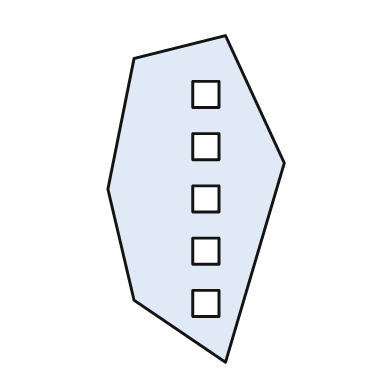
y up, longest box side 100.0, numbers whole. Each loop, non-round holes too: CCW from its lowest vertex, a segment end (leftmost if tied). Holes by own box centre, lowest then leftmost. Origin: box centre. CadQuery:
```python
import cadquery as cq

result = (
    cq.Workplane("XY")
    .moveTo(9.0, -50.0)
    .lineTo(27.0, 11.0)
    .lineTo(9.0, 50.0)
    .lineTo(-19.0, 43.0)
    .lineTo(-27.0, 3.0)
    .lineTo(-19.0, -31.0)
    .close()
    .moveTo(-1.0, -36.0)
    .lineTo(7.0, -36.0)
    .lineTo(7.0, -28.0)
    .lineTo(-1.0, -28.0)
    .close()
    .moveTo(-1.0, -20.0)
    .lineTo(7.0, -20.0)
    .lineTo(7.0, -12.0)
    .lineTo(-1.0, -12.0)
    .close()
    .moveTo(-1.0, -4.0)
    .lineTo(7.0, -4.0)
    .lineTo(7.0, 4.0)
    .lineTo(-1.0, 4.0)
    .close()
    .moveTo(-1.0, 12.0)
    .lineTo(7.0, 12.0)
    .lineTo(7.0, 20.0)
    .lineTo(-1.0, 20.0)
    .close()
    .moveTo(-1.0, 28.0)
    .lineTo(7.0, 28.0)
    .lineTo(7.0, 36.0)
    .lineTo(-1.0, 36.0)
    .close()
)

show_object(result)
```